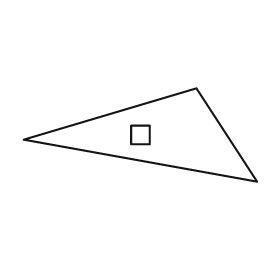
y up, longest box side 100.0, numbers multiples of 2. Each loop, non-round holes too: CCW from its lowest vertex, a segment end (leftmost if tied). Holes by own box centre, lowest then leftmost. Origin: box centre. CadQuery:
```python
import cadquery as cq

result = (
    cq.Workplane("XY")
    .moveTo(50.0, -20.0)
    .lineTo(24.0, 20.0)
    .lineTo(-50.0, -2.0)
    .close()
    .moveTo(-4.0, -4.0)
    .lineTo(4.0, -4.0)
    .lineTo(4.0, 4.0)
    .lineTo(-4.0, 4.0)
    .close()
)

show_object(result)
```